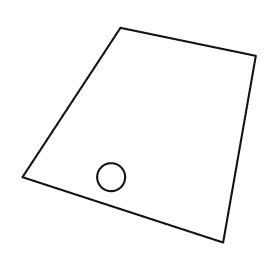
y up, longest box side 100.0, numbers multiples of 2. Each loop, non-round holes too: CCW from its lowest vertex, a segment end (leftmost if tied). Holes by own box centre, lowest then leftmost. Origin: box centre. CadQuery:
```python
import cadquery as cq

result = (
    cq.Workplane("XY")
    .moveTo(36.0, -46.0)
    .lineTo(50.0, 34.0)
    .lineTo(-8.0, 46.0)
    .lineTo(-50.0, -18.0)
    .close()
    .moveTo(-12.0, -18.0)
    .circle(6.0)
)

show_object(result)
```